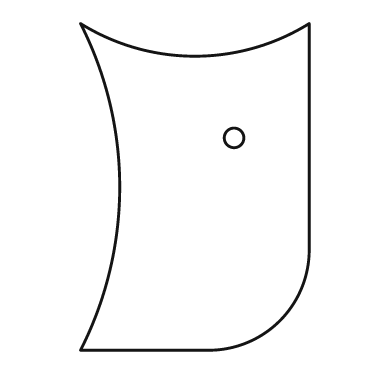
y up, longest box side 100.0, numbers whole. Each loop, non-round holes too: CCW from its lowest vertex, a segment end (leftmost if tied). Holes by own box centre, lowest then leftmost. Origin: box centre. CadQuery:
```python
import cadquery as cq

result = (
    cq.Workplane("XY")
    .moveTo(-35.0, -50.0)
    .lineTo(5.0, -50.0)
    .threePointArc((26.0, -41.0), (35.0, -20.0))
    .lineTo(35.0, 50.0)
    .threePointArc((0.0, 40.0), (-35.0, 50.0))
    .threePointArc((-23.0, 0.0), (-35.0, -50.0))
    .close()
    .moveTo(12.0, 15.0)
    .circle(3.0)
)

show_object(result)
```